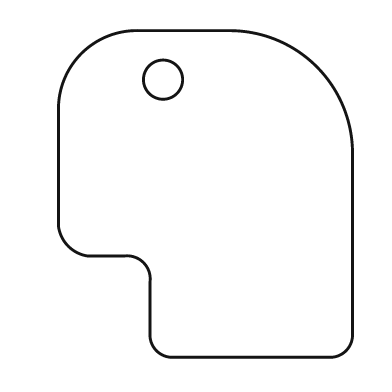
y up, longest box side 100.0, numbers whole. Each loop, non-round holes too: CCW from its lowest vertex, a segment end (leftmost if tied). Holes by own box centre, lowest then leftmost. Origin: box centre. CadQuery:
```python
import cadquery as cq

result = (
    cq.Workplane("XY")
    .moveTo(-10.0, -50.0)
    .lineTo(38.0, -50.0)
    .threePointArc((43.0, -48.0), (45.0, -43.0))
    .lineTo(45.0, 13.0)
    .threePointArc((34.0, 39.0), (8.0, 50.0))
    .lineTo(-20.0, 50.0)
    .threePointArc((-38.0, 43.0), (-45.0, 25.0))
    .lineTo(-45.0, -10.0)
    .threePointArc((-42.0, -16.0), (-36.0, -19.0))
    .lineTo(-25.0, -19.0)
    .threePointArc((-19.0, -21.0), (-17.0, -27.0))
    .lineTo(-17.0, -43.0)
    .threePointArc((-15.0, -48.0), (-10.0, -50.0))
    .close()
    .moveTo(-13.0, 35.0)
    .circle(6.0)
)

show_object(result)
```